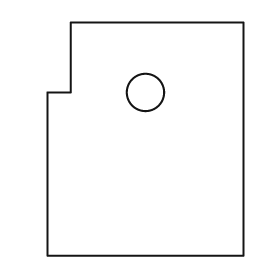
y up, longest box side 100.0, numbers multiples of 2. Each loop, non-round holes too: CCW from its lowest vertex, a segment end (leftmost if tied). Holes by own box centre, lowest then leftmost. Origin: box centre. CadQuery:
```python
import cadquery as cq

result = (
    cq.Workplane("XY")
    .moveTo(-42.0, -50.0)
    .lineTo(42.0, -50.0)
    .lineTo(42.0, 50.0)
    .lineTo(-32.0, 50.0)
    .lineTo(-32.0, 20.0)
    .lineTo(-42.0, 20.0)
    .close()
    .moveTo(0.0, 20.0)
    .circle(8.0)
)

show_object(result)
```